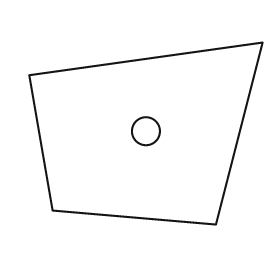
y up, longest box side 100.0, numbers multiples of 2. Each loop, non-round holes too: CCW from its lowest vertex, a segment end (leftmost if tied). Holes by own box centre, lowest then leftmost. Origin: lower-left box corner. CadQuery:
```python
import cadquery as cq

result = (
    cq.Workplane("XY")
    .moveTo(80.0, 0.0)
    .lineTo(100.0, 78.0)
    .lineTo(0.0, 64.0)
    .lineTo(10.0, 6.0)
    .close()
    .moveTo(50.0, 40.0)
    .circle(6.0)
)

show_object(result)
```